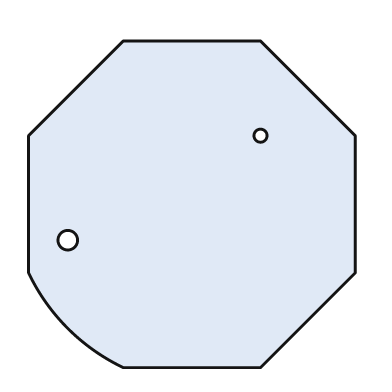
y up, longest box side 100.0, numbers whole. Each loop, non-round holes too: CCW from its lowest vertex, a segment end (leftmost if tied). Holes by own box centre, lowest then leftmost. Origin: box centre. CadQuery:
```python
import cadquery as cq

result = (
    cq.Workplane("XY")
    .moveTo(-21.0, -50.0)
    .lineTo(21.0, -50.0)
    .lineTo(50.0, -21.0)
    .lineTo(50.0, 21.0)
    .lineTo(21.0, 50.0)
    .lineTo(-21.0, 50.0)
    .lineTo(-50.0, 21.0)
    .lineTo(-50.0, -21.0)
    .threePointArc((-38.0, -38.0), (-21.0, -50.0))
    .close()
    .moveTo(-38.0, -11.0)
    .circle(3.0)
    .moveTo(21.0, 21.0)
    .circle(2.0)
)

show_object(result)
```